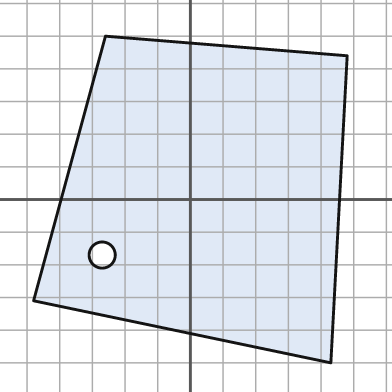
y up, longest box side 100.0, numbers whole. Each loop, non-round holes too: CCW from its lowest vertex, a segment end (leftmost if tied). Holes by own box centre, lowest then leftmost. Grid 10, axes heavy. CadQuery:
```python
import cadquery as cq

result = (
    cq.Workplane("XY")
    .moveTo(43.0, -50.0)
    .lineTo(48.0, 44.0)
    .lineTo(-26.0, 50.0)
    .lineTo(-48.0, -31.0)
    .close()
    .moveTo(-27.0, -17.0)
    .circle(4.0)
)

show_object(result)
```